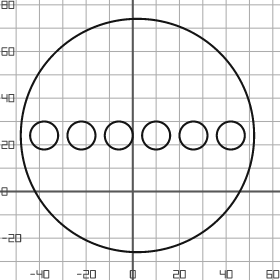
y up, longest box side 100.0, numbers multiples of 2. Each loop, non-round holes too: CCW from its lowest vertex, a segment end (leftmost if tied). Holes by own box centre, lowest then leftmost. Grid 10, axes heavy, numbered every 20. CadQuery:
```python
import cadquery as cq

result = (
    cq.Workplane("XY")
    .moveTo(2.0, 24.0)
    .circle(50.0)
    .moveTo(-38.0, 24.0)
    .circle(6.0)
    .moveTo(-22.0, 24.0)
    .circle(6.0)
    .moveTo(-6.0, 24.0)
    .circle(6.0)
    .moveTo(10.0, 24.0)
    .circle(6.0)
    .moveTo(26.0, 24.0)
    .circle(6.0)
    .moveTo(42.0, 24.0)
    .circle(6.0)
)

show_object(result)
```